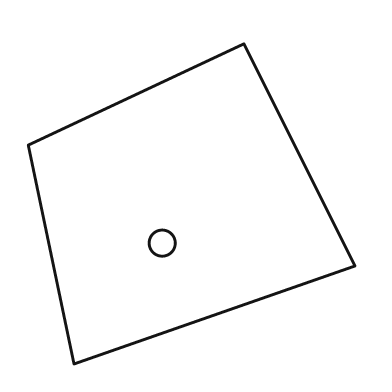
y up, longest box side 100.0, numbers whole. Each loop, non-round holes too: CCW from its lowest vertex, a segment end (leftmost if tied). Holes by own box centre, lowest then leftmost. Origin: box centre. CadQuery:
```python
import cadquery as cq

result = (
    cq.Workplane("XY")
    .moveTo(-36.0, -49.0)
    .lineTo(50.0, -19.0)
    .lineTo(16.0, 49.0)
    .lineTo(-50.0, 18.0)
    .close()
    .moveTo(-9.0, -12.0)
    .circle(4.0)
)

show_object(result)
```